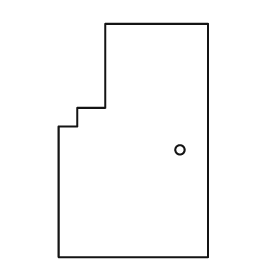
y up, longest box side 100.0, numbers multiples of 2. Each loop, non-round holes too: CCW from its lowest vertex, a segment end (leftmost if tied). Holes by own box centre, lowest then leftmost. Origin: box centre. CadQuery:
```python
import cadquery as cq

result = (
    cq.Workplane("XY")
    .moveTo(-32.0, -50.0)
    .lineTo(32.0, -50.0)
    .lineTo(32.0, 50.0)
    .lineTo(-12.0, 50.0)
    .lineTo(-12.0, 14.0)
    .lineTo(-24.0, 14.0)
    .lineTo(-24.0, 6.0)
    .lineTo(-32.0, 6.0)
    .close()
    .moveTo(20.0, -4.0)
    .circle(2.0)
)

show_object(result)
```